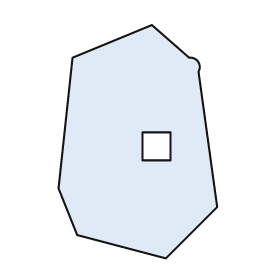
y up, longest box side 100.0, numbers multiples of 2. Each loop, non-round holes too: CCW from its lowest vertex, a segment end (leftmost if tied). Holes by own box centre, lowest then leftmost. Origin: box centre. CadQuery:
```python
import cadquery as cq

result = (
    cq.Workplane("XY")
    .moveTo(12.0, -50.0)
    .lineTo(34.0, -28.0)
    .lineTo(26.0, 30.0)
    .threePointArc((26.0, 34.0), (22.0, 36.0))
    .lineTo(6.0, 50.0)
    .lineTo(-28.0, 36.0)
    .lineTo(-34.0, -20.0)
    .lineTo(-26.0, -40.0)
    .close()
    .moveTo(2.0, -8.0)
    .lineTo(14.0, -8.0)
    .lineTo(14.0, 4.0)
    .lineTo(2.0, 4.0)
    .close()
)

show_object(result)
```